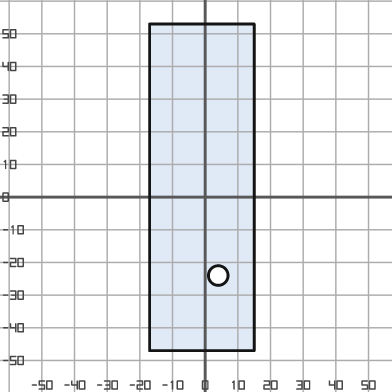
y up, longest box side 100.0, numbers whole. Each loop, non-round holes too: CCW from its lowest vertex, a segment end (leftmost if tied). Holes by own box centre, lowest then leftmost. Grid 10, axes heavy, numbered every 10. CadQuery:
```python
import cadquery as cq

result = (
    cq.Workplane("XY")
    .moveTo(-17.0, -47.0)
    .lineTo(15.0, -47.0)
    .lineTo(15.0, 53.0)
    .lineTo(-17.0, 53.0)
    .close()
    .moveTo(4.0, -24.0)
    .circle(3.0)
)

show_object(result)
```